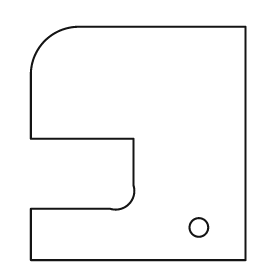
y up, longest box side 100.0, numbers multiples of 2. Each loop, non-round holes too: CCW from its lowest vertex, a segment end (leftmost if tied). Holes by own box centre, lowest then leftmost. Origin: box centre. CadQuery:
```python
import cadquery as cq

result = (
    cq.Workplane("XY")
    .moveTo(-46.0, -50.0)
    .lineTo(46.0, -50.0)
    .lineTo(46.0, 50.0)
    .lineTo(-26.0, 50.0)
    .threePointArc((-40.0, 44.0), (-46.0, 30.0))
    .lineTo(-46.0, 2.0)
    .lineTo(-2.0, 2.0)
    .lineTo(-2.0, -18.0)
    .threePointArc((-4.0, -26.0), (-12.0, -28.0))
    .lineTo(-46.0, -28.0)
    .close()
    .moveTo(26.0, -36.0)
    .circle(4.0)
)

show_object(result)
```